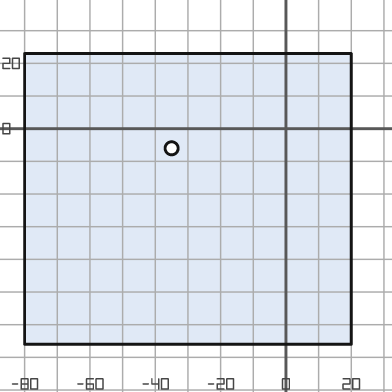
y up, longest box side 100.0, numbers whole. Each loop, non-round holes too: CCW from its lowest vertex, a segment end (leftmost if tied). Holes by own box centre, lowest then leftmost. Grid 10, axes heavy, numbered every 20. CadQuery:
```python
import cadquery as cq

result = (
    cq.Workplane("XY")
    .moveTo(-80.0, -66.0)
    .lineTo(20.0, -66.0)
    .lineTo(20.0, 23.0)
    .lineTo(-80.0, 23.0)
    .close()
    .moveTo(-35.0, -6.0)
    .circle(2.0)
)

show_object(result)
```